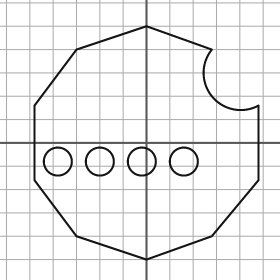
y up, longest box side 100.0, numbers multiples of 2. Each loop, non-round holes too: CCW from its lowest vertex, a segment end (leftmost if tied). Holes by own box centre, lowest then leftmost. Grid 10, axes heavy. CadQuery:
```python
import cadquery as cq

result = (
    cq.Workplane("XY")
    .moveTo(0.0, -50.0)
    .lineTo(28.0, -40.0)
    .lineTo(48.0, -16.0)
    .lineTo(48.0, 16.0)
    .threePointArc((28.0, 20.0), (28.0, 40.0))
    .lineTo(0.0, 50.0)
    .lineTo(-30.0, 40.0)
    .lineTo(-48.0, 16.0)
    .lineTo(-48.0, -16.0)
    .lineTo(-30.0, -40.0)
    .close()
    .moveTo(-38.0, -8.0)
    .circle(6.0)
    .moveTo(-20.0, -8.0)
    .circle(6.0)
    .moveTo(-2.0, -8.0)
    .circle(6.0)
    .moveTo(16.0, -8.0)
    .circle(6.0)
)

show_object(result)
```